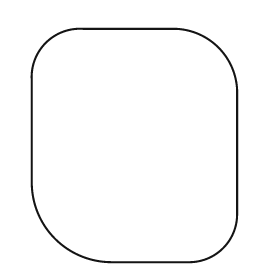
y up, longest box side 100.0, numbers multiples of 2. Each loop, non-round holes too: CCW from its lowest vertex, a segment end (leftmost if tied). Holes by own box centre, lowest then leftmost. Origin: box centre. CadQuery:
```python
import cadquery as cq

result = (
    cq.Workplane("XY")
    .moveTo(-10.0, -50.0)
    .lineTo(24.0, -50.0)
    .threePointArc((38.0, -44.0), (44.0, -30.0))
    .lineTo(44.0, 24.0)
    .threePointArc((36.0, 42.0), (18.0, 50.0))
    .lineTo(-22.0, 50.0)
    .threePointArc((-38.0, 44.0), (-44.0, 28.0))
    .lineTo(-44.0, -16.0)
    .threePointArc((-34.0, -40.0), (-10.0, -50.0))
    .close()
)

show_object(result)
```